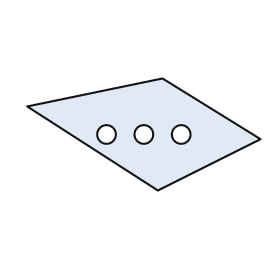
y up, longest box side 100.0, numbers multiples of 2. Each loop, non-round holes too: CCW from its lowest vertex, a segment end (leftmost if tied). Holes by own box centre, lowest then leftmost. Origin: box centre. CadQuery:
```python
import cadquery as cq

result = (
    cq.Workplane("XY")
    .moveTo(6.0, -24.0)
    .lineTo(50.0, -2.0)
    .lineTo(8.0, 24.0)
    .lineTo(-50.0, 12.0)
    .close()
    .moveTo(-16.0, 0.0)
    .circle(4.0)
    .moveTo(0.0, 0.0)
    .circle(4.0)
    .moveTo(16.0, 0.0)
    .circle(4.0)
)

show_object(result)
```